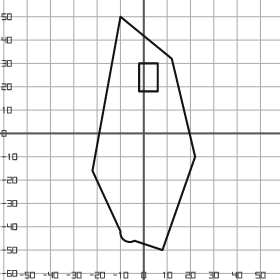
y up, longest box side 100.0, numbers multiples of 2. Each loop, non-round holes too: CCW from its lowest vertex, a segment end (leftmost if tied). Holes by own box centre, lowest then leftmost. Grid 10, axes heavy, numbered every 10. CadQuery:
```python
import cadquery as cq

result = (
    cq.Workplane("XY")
    .moveTo(8.0, -50.0)
    .lineTo(22.0, -10.0)
    .lineTo(12.0, 32.0)
    .lineTo(-10.0, 50.0)
    .lineTo(-22.0, -16.0)
    .lineTo(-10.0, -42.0)
    .threePointArc((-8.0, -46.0), (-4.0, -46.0))
    .close()
    .moveTo(-2.0, 18.0)
    .lineTo(6.0, 18.0)
    .lineTo(6.0, 30.0)
    .lineTo(-2.0, 30.0)
    .close()
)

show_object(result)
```